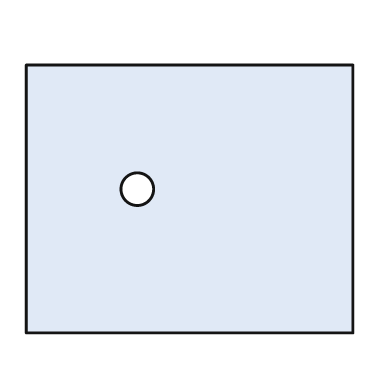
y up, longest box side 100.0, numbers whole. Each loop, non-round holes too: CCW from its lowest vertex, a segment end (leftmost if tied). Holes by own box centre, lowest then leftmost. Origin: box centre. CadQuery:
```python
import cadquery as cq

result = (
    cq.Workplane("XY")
    .moveTo(-50.0, -41.0)
    .lineTo(50.0, -41.0)
    .lineTo(50.0, 41.0)
    .lineTo(-50.0, 41.0)
    .close()
    .moveTo(-16.0, 3.0)
    .circle(5.0)
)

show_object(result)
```